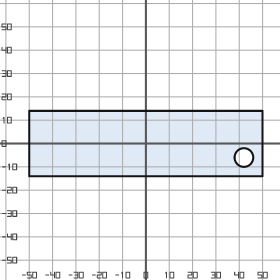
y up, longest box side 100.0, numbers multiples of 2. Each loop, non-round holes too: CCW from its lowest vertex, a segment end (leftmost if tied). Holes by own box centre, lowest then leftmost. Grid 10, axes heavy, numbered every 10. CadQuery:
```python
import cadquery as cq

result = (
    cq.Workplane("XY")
    .moveTo(-50.0, -14.0)
    .lineTo(50.0, -14.0)
    .lineTo(50.0, 14.0)
    .lineTo(-50.0, 14.0)
    .close()
    .moveTo(42.0, -6.0)
    .circle(4.0)
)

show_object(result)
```